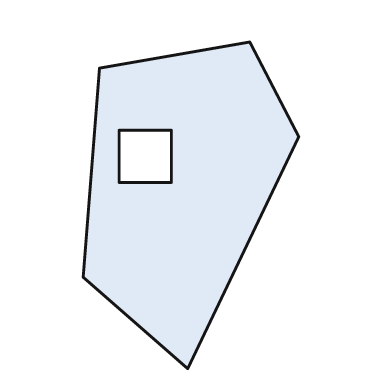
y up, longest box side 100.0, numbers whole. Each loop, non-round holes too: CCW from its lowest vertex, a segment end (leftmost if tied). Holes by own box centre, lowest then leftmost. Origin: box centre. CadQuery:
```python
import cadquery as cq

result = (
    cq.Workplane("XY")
    .moveTo(-1.0, -50.0)
    .lineTo(33.0, 21.0)
    .lineTo(18.0, 50.0)
    .lineTo(-28.0, 42.0)
    .lineTo(-33.0, -22.0)
    .close()
    .moveTo(-22.0, 7.0)
    .lineTo(-6.0, 7.0)
    .lineTo(-6.0, 23.0)
    .lineTo(-22.0, 23.0)
    .close()
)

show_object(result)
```